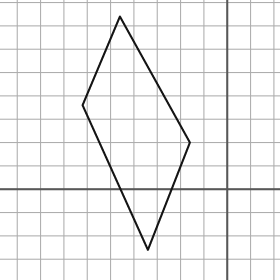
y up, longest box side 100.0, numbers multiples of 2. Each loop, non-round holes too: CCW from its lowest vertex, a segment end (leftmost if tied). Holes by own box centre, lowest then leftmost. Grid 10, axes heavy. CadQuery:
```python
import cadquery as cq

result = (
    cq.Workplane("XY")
    .moveTo(-34.0, -26.0)
    .lineTo(-16.0, 20.0)
    .lineTo(-46.0, 74.0)
    .lineTo(-62.0, 36.0)
    .close()
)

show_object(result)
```